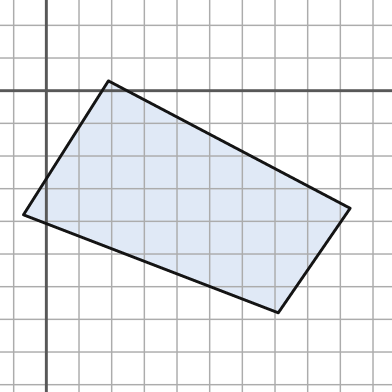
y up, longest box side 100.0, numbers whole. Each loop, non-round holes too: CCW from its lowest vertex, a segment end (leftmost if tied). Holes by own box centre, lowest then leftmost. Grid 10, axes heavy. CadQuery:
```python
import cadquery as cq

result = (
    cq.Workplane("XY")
    .moveTo(71.0, -68.0)
    .lineTo(93.0, -36.0)
    .lineTo(19.0, 3.0)
    .lineTo(-7.0, -38.0)
    .close()
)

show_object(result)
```